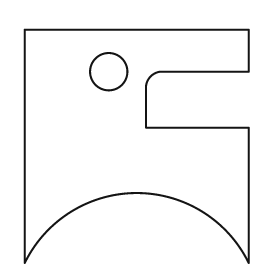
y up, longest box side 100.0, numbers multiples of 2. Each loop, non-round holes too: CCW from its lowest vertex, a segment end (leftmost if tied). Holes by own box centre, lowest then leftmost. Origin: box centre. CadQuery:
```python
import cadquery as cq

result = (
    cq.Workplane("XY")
    .moveTo(-48.0, -50.0)
    .threePointArc((0.0, -20.0), (48.0, -50.0))
    .lineTo(48.0, 8.0)
    .lineTo(4.0, 8.0)
    .lineTo(4.0, 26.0)
    .threePointArc((6.0, 30.0), (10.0, 32.0))
    .lineTo(48.0, 32.0)
    .lineTo(48.0, 50.0)
    .lineTo(-48.0, 50.0)
    .close()
    .moveTo(-12.0, 32.0)
    .circle(8.0)
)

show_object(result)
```